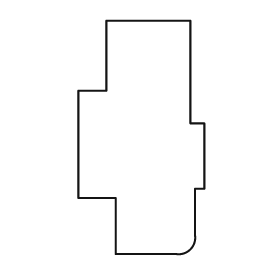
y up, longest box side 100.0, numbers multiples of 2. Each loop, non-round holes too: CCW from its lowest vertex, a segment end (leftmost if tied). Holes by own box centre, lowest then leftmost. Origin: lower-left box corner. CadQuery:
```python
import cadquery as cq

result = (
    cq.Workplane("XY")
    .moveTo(16.0, 0.0)
    .lineTo(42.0, 0.0)
    .threePointArc((48.0, 2.0), (50.0, 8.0))
    .lineTo(50.0, 28.0)
    .lineTo(54.0, 28.0)
    .lineTo(54.0, 56.0)
    .lineTo(48.0, 56.0)
    .lineTo(48.0, 100.0)
    .lineTo(12.0, 100.0)
    .lineTo(12.0, 70.0)
    .lineTo(0.0, 70.0)
    .lineTo(0.0, 24.0)
    .lineTo(16.0, 24.0)
    .close()
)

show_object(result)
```